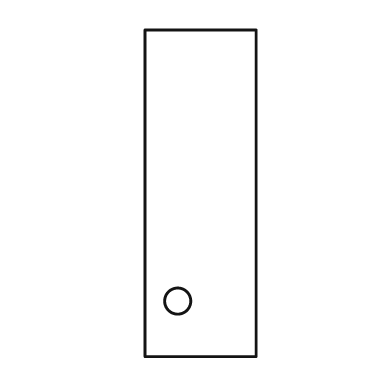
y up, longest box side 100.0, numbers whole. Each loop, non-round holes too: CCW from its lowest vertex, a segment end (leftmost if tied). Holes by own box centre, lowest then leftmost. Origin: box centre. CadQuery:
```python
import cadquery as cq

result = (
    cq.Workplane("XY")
    .moveTo(-17.0, -50.0)
    .lineTo(17.0, -50.0)
    .lineTo(17.0, 50.0)
    .lineTo(-17.0, 50.0)
    .close()
    .moveTo(-7.0, -33.0)
    .circle(4.0)
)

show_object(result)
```